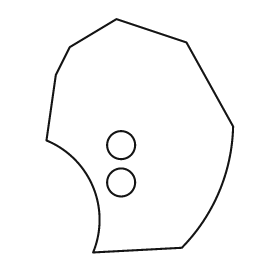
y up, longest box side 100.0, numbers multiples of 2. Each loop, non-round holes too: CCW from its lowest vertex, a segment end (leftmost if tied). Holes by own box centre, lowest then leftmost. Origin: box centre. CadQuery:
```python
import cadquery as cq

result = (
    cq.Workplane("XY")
    .moveTo(-20.0, -50.0)
    .lineTo(18.0, -48.0)
    .threePointArc((34.0, -24.0), (40.0, 4.0))
    .lineTo(20.0, 40.0)
    .lineTo(-10.0, 50.0)
    .lineTo(-30.0, 38.0)
    .lineTo(-36.0, 26.0)
    .lineTo(-40.0, -2.0)
    .threePointArc((-20.0, -22.0), (-20.0, -50.0))
    .close()
    .moveTo(-8.0, -20.0)
    .circle(6.0)
    .moveTo(-8.0, -4.0)
    .circle(6.0)
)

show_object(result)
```